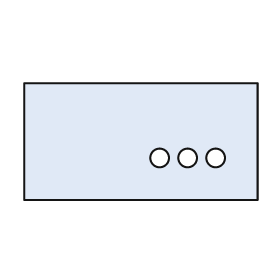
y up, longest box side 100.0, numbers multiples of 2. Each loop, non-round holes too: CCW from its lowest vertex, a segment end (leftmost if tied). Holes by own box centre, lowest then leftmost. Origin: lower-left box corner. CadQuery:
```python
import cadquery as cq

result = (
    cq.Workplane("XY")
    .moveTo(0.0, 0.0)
    .lineTo(100.0, 0.0)
    .lineTo(100.0, 50.0)
    .lineTo(0.0, 50.0)
    .close()
    .moveTo(58.0, 18.0)
    .circle(4.0)
    .moveTo(70.0, 18.0)
    .circle(4.0)
    .moveTo(82.0, 18.0)
    .circle(4.0)
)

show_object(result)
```